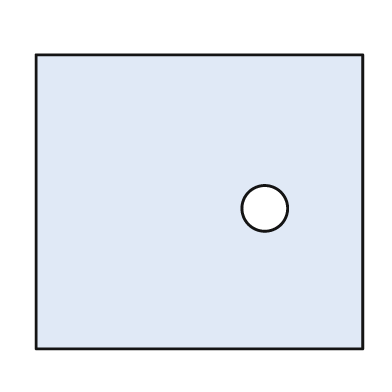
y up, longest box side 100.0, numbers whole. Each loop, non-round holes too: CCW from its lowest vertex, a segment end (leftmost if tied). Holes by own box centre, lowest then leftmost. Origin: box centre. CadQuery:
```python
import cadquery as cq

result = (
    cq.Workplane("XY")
    .moveTo(-50.0, -45.0)
    .lineTo(50.0, -45.0)
    .lineTo(50.0, 45.0)
    .lineTo(-50.0, 45.0)
    .close()
    .moveTo(20.0, -2.0)
    .circle(7.0)
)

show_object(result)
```